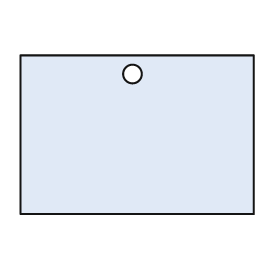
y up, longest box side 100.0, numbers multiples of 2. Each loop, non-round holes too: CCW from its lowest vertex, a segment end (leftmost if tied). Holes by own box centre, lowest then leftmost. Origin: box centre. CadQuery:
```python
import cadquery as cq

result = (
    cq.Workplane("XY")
    .moveTo(-50.0, -34.0)
    .lineTo(50.0, -34.0)
    .lineTo(50.0, 34.0)
    .lineTo(-50.0, 34.0)
    .close()
    .moveTo(-2.0, 26.0)
    .circle(4.0)
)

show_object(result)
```